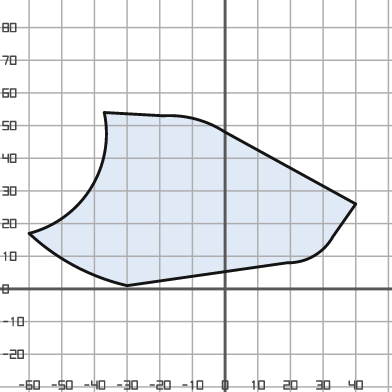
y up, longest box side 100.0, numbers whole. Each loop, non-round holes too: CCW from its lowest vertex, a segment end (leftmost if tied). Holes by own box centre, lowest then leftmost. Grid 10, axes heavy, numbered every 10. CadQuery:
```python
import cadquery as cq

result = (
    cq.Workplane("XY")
    .moveTo(-30.0, 1.0)
    .lineTo(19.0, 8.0)
    .threePointArc((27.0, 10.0), (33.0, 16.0))
    .lineTo(40.0, 26.0)
    .lineTo(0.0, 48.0)
    .threePointArc((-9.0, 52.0), (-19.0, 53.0))
    .lineTo(-37.0, 54.0)
    .threePointArc((-41.0, 31.0), (-60.0, 17.0))
    .threePointArc((-46.0, 7.0), (-30.0, 1.0))
    .close()
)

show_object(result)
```